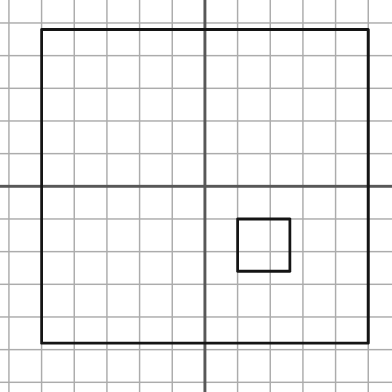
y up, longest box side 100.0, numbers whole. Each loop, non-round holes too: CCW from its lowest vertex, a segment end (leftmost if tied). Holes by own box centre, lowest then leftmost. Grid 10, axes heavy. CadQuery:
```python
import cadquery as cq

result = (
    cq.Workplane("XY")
    .moveTo(-50.0, -48.0)
    .lineTo(50.0, -48.0)
    .lineTo(50.0, 48.0)
    .lineTo(-50.0, 48.0)
    .close()
    .moveTo(10.0, -26.0)
    .lineTo(26.0, -26.0)
    .lineTo(26.0, -10.0)
    .lineTo(10.0, -10.0)
    .close()
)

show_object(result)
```